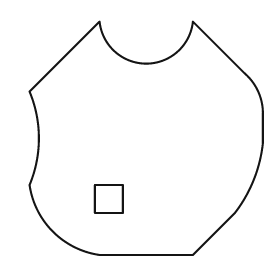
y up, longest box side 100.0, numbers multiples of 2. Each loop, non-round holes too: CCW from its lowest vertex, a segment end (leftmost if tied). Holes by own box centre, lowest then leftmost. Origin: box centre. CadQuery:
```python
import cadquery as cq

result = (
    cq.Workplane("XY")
    .moveTo(-20.0, -50.0)
    .lineTo(20.0, -50.0)
    .lineTo(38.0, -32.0)
    .threePointArc((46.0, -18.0), (50.0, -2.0))
    .lineTo(50.0, 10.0)
    .threePointArc((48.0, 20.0), (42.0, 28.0))
    .lineTo(20.0, 50.0)
    .threePointArc((0.0, 32.0), (-20.0, 50.0))
    .lineTo(-50.0, 20.0)
    .threePointArc((-46.0, 0.0), (-50.0, -20.0))
    .threePointArc((-40.0, -40.0), (-20.0, -50.0))
    .close()
    .moveTo(-22.0, -32.0)
    .lineTo(-10.0, -32.0)
    .lineTo(-10.0, -20.0)
    .lineTo(-22.0, -20.0)
    .close()
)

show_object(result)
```